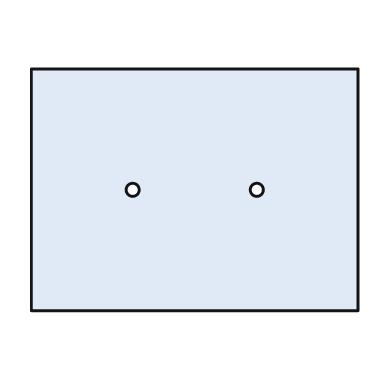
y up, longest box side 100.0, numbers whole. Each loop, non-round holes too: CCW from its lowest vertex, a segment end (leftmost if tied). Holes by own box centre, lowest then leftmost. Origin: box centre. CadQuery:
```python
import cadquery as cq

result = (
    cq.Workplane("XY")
    .moveTo(-50.0, -37.0)
    .lineTo(50.0, -37.0)
    .lineTo(50.0, 37.0)
    .lineTo(-50.0, 37.0)
    .close()
    .moveTo(-19.0, 0.0)
    .circle(2.0)
    .moveTo(19.0, 0.0)
    .circle(2.0)
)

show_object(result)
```